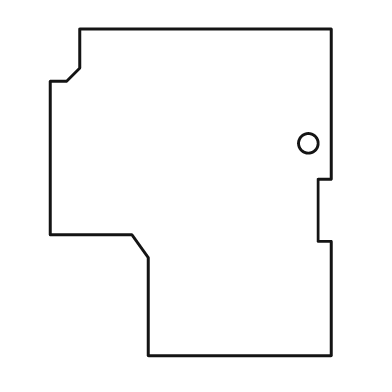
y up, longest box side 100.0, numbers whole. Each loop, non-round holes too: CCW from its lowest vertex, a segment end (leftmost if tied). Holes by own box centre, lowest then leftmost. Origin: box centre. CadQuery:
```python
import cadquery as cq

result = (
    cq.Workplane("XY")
    .moveTo(-13.0, -50.0)
    .lineTo(43.0, -50.0)
    .lineTo(43.0, -15.0)
    .lineTo(39.0, -15.0)
    .lineTo(39.0, 4.0)
    .lineTo(43.0, 4.0)
    .lineTo(43.0, 50.0)
    .lineTo(-34.0, 50.0)
    .lineTo(-34.0, 38.0)
    .lineTo(-38.0, 34.0)
    .lineTo(-43.0, 34.0)
    .lineTo(-43.0, -13.0)
    .lineTo(-18.0, -13.0)
    .lineTo(-13.0, -20.0)
    .close()
    .moveTo(36.0, 15.0)
    .circle(3.0)
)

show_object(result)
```